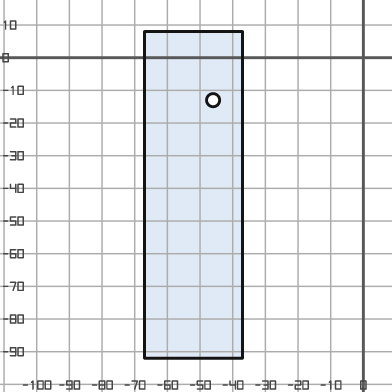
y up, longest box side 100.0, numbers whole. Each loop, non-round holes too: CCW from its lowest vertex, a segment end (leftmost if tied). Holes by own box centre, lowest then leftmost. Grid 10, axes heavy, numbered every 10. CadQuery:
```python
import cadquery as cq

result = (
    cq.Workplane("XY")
    .moveTo(-67.0, -92.0)
    .lineTo(-37.0, -92.0)
    .lineTo(-37.0, 8.0)
    .lineTo(-67.0, 8.0)
    .close()
    .moveTo(-46.0, -13.0)
    .circle(2.0)
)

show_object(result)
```